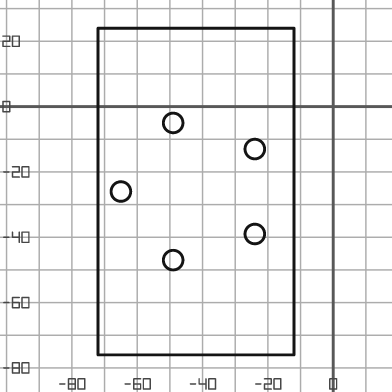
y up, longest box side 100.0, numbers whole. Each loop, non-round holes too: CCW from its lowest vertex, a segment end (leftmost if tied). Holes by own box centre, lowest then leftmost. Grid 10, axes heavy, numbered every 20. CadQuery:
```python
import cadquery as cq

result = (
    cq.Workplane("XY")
    .moveTo(-72.0, -76.0)
    .lineTo(-12.0, -76.0)
    .lineTo(-12.0, 24.0)
    .lineTo(-72.0, 24.0)
    .close()
    .moveTo(-49.0, -47.0)
    .circle(3.0)
    .moveTo(-24.0, -39.0)
    .circle(3.0)
    .moveTo(-65.0, -26.0)
    .circle(3.0)
    .moveTo(-24.0, -13.0)
    .circle(3.0)
    .moveTo(-49.0, -5.0)
    .circle(3.0)
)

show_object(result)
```